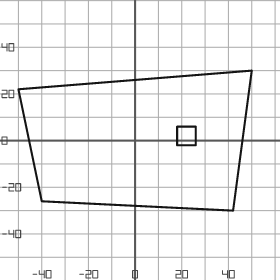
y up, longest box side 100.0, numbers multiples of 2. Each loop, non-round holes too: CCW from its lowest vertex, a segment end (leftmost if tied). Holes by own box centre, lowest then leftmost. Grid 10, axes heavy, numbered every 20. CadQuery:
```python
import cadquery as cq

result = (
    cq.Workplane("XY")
    .moveTo(42.0, -30.0)
    .lineTo(50.0, 30.0)
    .lineTo(-50.0, 22.0)
    .lineTo(-40.0, -26.0)
    .close()
    .moveTo(18.0, -2.0)
    .lineTo(26.0, -2.0)
    .lineTo(26.0, 6.0)
    .lineTo(18.0, 6.0)
    .close()
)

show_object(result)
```